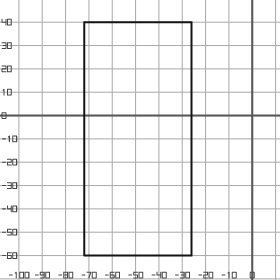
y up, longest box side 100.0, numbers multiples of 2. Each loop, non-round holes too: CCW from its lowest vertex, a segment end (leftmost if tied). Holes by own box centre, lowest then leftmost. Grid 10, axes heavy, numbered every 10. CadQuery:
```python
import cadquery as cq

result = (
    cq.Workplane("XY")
    .moveTo(-72.0, -60.0)
    .lineTo(-26.0, -60.0)
    .lineTo(-26.0, 40.0)
    .lineTo(-72.0, 40.0)
    .close()
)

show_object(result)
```